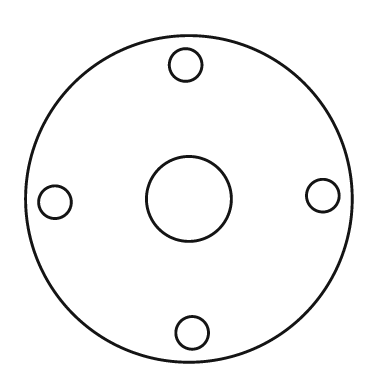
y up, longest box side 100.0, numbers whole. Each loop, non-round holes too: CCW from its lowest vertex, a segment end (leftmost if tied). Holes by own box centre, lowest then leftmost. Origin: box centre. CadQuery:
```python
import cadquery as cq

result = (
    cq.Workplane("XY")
    .moveTo(0.0, 0.0)
    .circle(50.0)
    .moveTo(1.0, -41.0)
    .circle(5.0)
    .moveTo(-41.0, -1.0)
    .circle(5.0)
    .moveTo(0.0, 0.0)
    .circle(13.0)
    .moveTo(41.0, 1.0)
    .circle(5.0)
    .moveTo(-1.0, 41.0)
    .circle(5.0)
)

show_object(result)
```